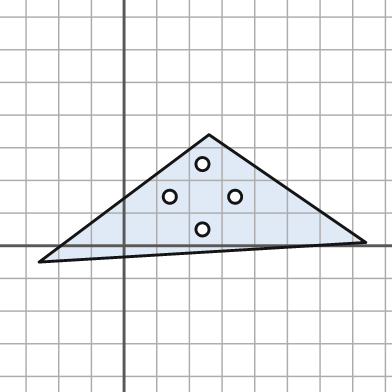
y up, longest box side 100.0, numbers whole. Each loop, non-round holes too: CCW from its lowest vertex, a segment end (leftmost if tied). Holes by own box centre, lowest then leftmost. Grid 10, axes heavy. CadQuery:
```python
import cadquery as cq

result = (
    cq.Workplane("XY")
    .moveTo(-26.0, -5.0)
    .lineTo(74.0, 1.0)
    .lineTo(26.0, 34.0)
    .close()
    .moveTo(24.0, 5.0)
    .circle(2.0)
    .moveTo(14.0, 15.0)
    .circle(2.0)
    .moveTo(34.0, 15.0)
    .circle(2.0)
    .moveTo(24.0, 25.0)
    .circle(2.0)
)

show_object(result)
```